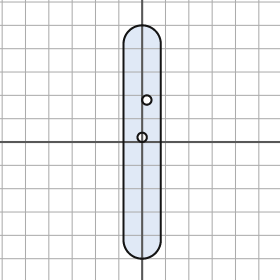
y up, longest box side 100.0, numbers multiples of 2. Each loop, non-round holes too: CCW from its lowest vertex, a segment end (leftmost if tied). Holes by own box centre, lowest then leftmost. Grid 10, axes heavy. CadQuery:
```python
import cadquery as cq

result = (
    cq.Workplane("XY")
    .moveTo(-8.0, -42.0)
    .threePointArc((0.0, -50.0), (8.0, -42.0))
    .lineTo(8.0, 42.0)
    .threePointArc((0.0, 50.0), (-8.0, 42.0))
    .close()
    .moveTo(0.0, 2.0)
    .circle(2.0)
    .moveTo(2.0, 18.0)
    .circle(2.0)
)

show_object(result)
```